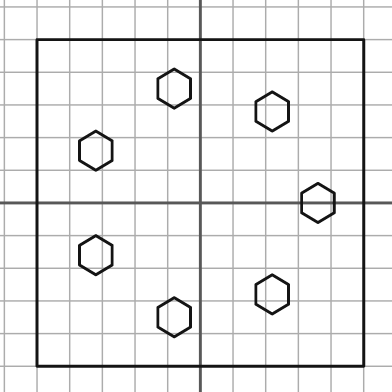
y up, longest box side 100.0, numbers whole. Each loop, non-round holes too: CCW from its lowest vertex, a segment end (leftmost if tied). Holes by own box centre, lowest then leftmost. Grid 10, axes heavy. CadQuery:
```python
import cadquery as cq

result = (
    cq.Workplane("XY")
    .moveTo(-50.0, -50.0)
    .lineTo(50.0, -50.0)
    .lineTo(50.0, 50.0)
    .lineTo(-50.0, 50.0)
    .close()
    .moveTo(-8.0, -41.0)
    .lineTo(-3.0, -38.0)
    .lineTo(-3.0, -32.0)
    .lineTo(-8.0, -29.0)
    .lineTo(-13.0, -32.0)
    .lineTo(-13.0, -38.0)
    .close()
    .moveTo(22.0, -34.0)
    .lineTo(27.0, -31.0)
    .lineTo(27.0, -25.0)
    .lineTo(22.0, -22.0)
    .lineTo(17.0, -25.0)
    .lineTo(17.0, -31.0)
    .close()
    .moveTo(-32.0, -22.0)
    .lineTo(-27.0, -19.0)
    .lineTo(-27.0, -13.0)
    .lineTo(-32.0, -10.0)
    .lineTo(-37.0, -13.0)
    .lineTo(-37.0, -19.0)
    .close()
    .moveTo(36.0, -6.0)
    .lineTo(41.0, -3.0)
    .lineTo(41.0, 3.0)
    .lineTo(36.0, 6.0)
    .lineTo(31.0, 3.0)
    .lineTo(31.0, -3.0)
    .close()
    .moveTo(-32.0, 10.0)
    .lineTo(-27.0, 13.0)
    .lineTo(-27.0, 19.0)
    .lineTo(-32.0, 22.0)
    .lineTo(-37.0, 19.0)
    .lineTo(-37.0, 13.0)
    .close()
    .moveTo(22.0, 22.0)
    .lineTo(27.0, 25.0)
    .lineTo(27.0, 31.0)
    .lineTo(22.0, 34.0)
    .lineTo(17.0, 31.0)
    .lineTo(17.0, 25.0)
    .close()
    .moveTo(-8.0, 29.0)
    .lineTo(-3.0, 32.0)
    .lineTo(-3.0, 38.0)
    .lineTo(-8.0, 41.0)
    .lineTo(-13.0, 38.0)
    .lineTo(-13.0, 32.0)
    .close()
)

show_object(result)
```